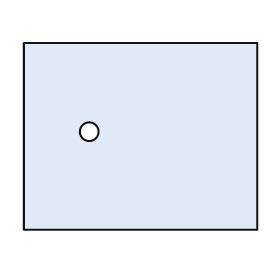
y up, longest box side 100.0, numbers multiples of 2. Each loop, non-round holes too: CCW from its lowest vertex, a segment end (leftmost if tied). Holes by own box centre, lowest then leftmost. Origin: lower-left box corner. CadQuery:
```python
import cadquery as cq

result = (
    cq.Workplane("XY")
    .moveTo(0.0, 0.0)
    .lineTo(100.0, 0.0)
    .lineTo(100.0, 80.0)
    .lineTo(0.0, 80.0)
    .close()
    .moveTo(28.0, 42.0)
    .circle(4.0)
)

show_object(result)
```